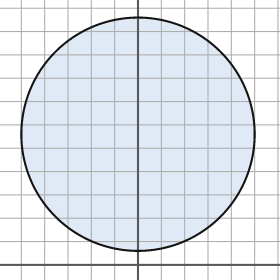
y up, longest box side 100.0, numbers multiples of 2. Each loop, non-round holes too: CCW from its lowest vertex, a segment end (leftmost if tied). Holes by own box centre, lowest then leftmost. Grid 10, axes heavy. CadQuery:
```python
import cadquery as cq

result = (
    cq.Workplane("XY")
    .moveTo(0.0, 56.0)
    .circle(50.0)
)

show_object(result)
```